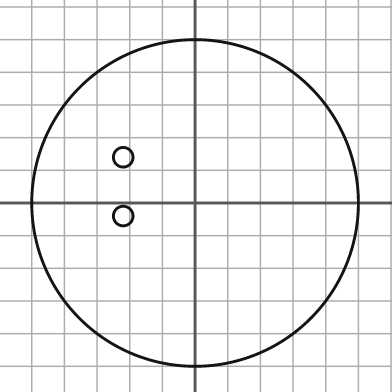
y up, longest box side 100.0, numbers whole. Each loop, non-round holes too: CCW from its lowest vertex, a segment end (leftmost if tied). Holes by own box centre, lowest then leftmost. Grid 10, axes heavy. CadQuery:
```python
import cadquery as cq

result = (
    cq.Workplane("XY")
    .moveTo(0.0, 0.0)
    .circle(50.0)
    .moveTo(-22.0, -4.0)
    .circle(3.0)
    .moveTo(-22.0, 14.0)
    .circle(3.0)
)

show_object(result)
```